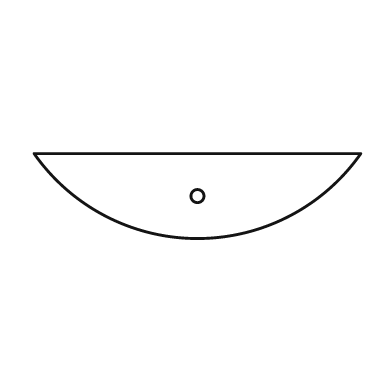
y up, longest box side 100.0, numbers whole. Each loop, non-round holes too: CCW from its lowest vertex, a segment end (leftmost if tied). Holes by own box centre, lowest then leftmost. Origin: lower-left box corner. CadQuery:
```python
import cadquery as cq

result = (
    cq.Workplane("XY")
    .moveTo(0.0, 26.0)
    .threePointArc((50.0, 0.0), (100.0, 26.0))
    .close()
    .moveTo(50.0, 13.0)
    .circle(2.0)
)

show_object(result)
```